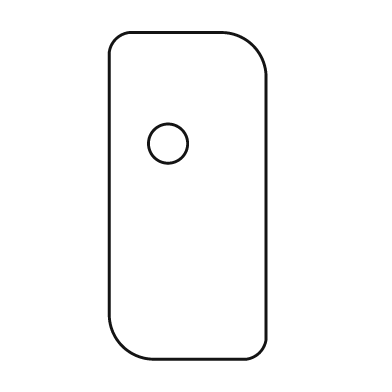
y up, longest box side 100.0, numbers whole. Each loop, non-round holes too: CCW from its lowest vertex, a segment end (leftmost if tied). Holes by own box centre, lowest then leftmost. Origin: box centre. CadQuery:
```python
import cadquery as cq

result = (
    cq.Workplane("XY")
    .moveTo(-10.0, -50.0)
    .lineTo(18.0, -50.0)
    .threePointArc((22.0, -48.0), (24.0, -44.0))
    .lineTo(24.0, 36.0)
    .threePointArc((20.0, 46.0), (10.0, 50.0))
    .lineTo(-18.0, 50.0)
    .threePointArc((-22.0, 48.0), (-24.0, 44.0))
    .lineTo(-24.0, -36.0)
    .threePointArc((-20.0, -46.0), (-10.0, -50.0))
    .close()
    .moveTo(-6.0, 16.0)
    .circle(6.0)
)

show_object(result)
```